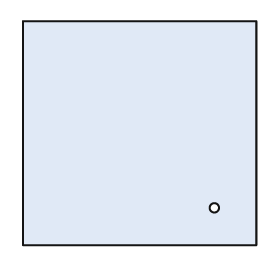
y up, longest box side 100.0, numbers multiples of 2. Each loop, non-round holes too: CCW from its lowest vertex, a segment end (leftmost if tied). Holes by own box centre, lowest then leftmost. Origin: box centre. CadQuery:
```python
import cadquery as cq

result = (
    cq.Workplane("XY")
    .moveTo(-50.0, -48.0)
    .lineTo(50.0, -48.0)
    .lineTo(50.0, 48.0)
    .lineTo(-50.0, 48.0)
    .close()
    .moveTo(32.0, -32.0)
    .circle(2.0)
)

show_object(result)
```